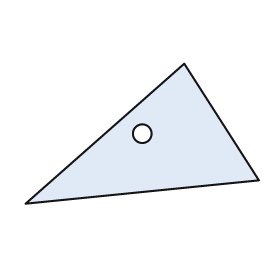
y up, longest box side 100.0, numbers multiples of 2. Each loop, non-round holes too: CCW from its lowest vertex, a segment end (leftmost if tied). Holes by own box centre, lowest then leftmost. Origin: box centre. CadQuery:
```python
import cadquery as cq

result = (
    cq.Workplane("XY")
    .moveTo(-50.0, -30.0)
    .lineTo(50.0, -20.0)
    .lineTo(18.0, 30.0)
    .close()
    .moveTo(0.0, 0.0)
    .circle(4.0)
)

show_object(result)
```